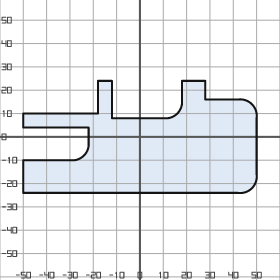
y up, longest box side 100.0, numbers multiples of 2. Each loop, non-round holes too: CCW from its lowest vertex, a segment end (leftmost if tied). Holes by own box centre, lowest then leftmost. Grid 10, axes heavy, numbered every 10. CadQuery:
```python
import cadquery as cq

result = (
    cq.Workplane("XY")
    .moveTo(-50.0, -24.0)
    .lineTo(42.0, -24.0)
    .threePointArc((48.0, -22.0), (50.0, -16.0))
    .lineTo(50.0, 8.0)
    .threePointArc((48.0, 14.0), (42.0, 16.0))
    .lineTo(28.0, 16.0)
    .lineTo(28.0, 24.0)
    .lineTo(18.0, 24.0)
    .lineTo(18.0, 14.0)
    .threePointArc((16.0, 10.0), (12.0, 8.0))
    .lineTo(-12.0, 8.0)
    .lineTo(-12.0, 24.0)
    .lineTo(-18.0, 24.0)
    .lineTo(-18.0, 10.0)
    .lineTo(-50.0, 10.0)
    .lineTo(-50.0, 4.0)
    .lineTo(-22.0, 4.0)
    .lineTo(-22.0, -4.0)
    .threePointArc((-24.0, -8.0), (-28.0, -10.0))
    .lineTo(-50.0, -10.0)
    .close()
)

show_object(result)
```